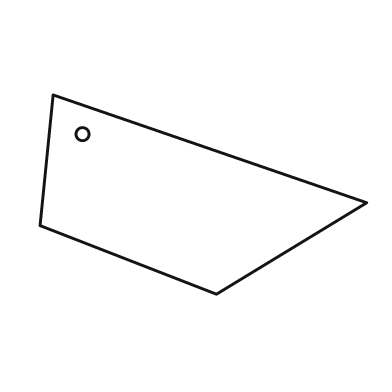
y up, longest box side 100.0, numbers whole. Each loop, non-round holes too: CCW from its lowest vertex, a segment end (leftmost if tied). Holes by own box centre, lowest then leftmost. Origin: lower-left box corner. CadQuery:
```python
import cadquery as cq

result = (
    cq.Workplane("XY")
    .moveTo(54.0, 0.0)
    .lineTo(100.0, 28.0)
    .lineTo(4.0, 61.0)
    .lineTo(0.0, 21.0)
    .close()
    .moveTo(13.0, 49.0)
    .circle(2.0)
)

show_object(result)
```